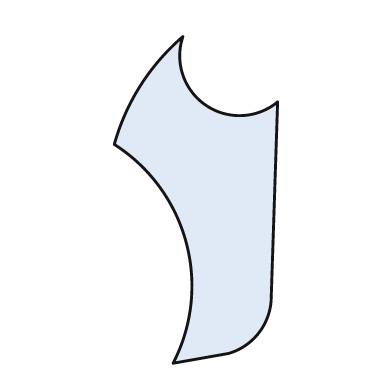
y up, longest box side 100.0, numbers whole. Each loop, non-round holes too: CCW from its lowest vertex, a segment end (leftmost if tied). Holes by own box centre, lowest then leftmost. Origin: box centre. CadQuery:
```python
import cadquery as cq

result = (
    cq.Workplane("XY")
    .moveTo(-7.0, -50.0)
    .lineTo(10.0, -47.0)
    .threePointArc((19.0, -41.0), (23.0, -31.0))
    .lineTo(25.0, 30.0)
    .threePointArc((3.0, 29.0), (-4.0, 50.0))
    .threePointArc((-17.0, 35.0), (-25.0, 17.0))
    .threePointArc((-3.0, -13.0), (-7.0, -50.0))
    .close()
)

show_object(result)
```